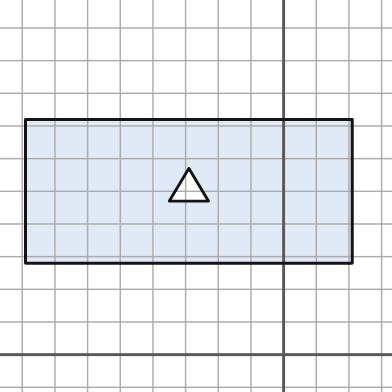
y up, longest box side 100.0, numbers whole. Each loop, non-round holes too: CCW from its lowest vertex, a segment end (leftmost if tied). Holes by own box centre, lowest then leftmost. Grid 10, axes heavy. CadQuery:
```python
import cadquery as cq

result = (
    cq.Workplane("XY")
    .moveTo(-79.0, 28.0)
    .lineTo(21.0, 28.0)
    .lineTo(21.0, 72.0)
    .lineTo(-79.0, 72.0)
    .close()
    .moveTo(-35.0, 47.0)
    .lineTo(-23.0, 47.0)
    .lineTo(-29.0, 57.0)
    .close()
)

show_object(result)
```